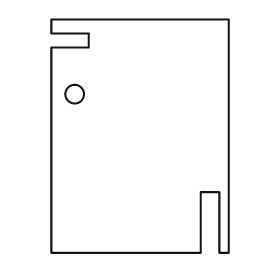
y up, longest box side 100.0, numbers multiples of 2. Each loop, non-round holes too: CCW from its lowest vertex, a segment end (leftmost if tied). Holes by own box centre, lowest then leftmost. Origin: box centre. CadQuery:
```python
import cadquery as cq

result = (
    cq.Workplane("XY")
    .moveTo(-38.0, -50.0)
    .lineTo(26.0, -50.0)
    .lineTo(26.0, -24.0)
    .lineTo(34.0, -24.0)
    .lineTo(34.0, -50.0)
    .lineTo(38.0, -50.0)
    .lineTo(38.0, 50.0)
    .lineTo(-38.0, 50.0)
    .lineTo(-38.0, 44.0)
    .lineTo(-22.0, 44.0)
    .lineTo(-22.0, 38.0)
    .lineTo(-38.0, 38.0)
    .close()
    .moveTo(-28.0, 18.0)
    .circle(4.0)
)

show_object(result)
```